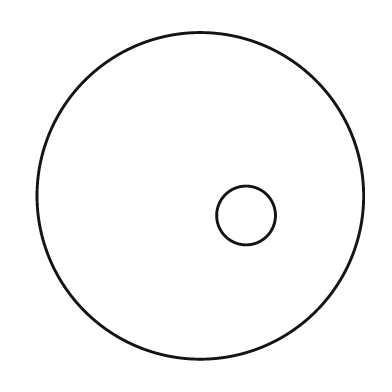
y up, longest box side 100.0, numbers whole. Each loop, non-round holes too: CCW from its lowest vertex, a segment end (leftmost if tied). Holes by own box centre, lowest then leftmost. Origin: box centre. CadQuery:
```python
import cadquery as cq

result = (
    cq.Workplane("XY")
    .moveTo(0.0, 0.0)
    .circle(50.0)
    .moveTo(14.0, -6.0)
    .circle(9.0)
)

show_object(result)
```